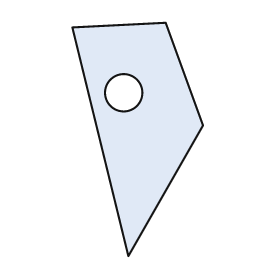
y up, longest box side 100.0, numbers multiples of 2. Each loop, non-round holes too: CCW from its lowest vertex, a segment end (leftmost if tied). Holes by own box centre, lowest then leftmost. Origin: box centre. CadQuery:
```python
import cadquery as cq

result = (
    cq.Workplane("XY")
    .moveTo(-4.0, -50.0)
    .lineTo(28.0, 6.0)
    .lineTo(12.0, 50.0)
    .lineTo(-28.0, 48.0)
    .close()
    .moveTo(-6.0, 20.0)
    .circle(8.0)
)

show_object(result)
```